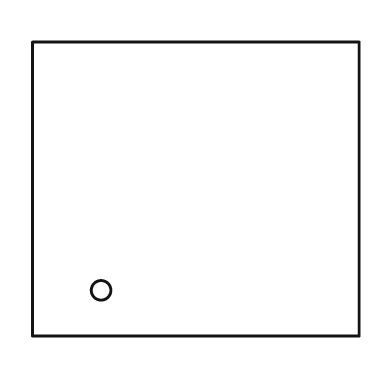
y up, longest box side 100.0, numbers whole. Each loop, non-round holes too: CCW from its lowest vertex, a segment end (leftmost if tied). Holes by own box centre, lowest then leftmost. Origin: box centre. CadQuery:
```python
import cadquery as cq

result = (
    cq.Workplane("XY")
    .moveTo(-50.0, -45.0)
    .lineTo(50.0, -45.0)
    .lineTo(50.0, 45.0)
    .lineTo(-50.0, 45.0)
    .close()
    .moveTo(-29.0, -31.0)
    .circle(3.0)
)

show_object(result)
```